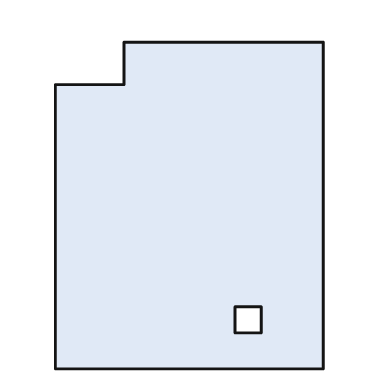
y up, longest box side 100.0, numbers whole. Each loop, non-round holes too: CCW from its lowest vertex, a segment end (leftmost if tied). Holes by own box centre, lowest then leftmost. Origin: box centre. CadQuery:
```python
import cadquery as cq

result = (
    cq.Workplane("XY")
    .moveTo(-41.0, -50.0)
    .lineTo(41.0, -50.0)
    .lineTo(41.0, 50.0)
    .lineTo(-20.0, 50.0)
    .lineTo(-20.0, 37.0)
    .lineTo(-41.0, 37.0)
    .close()
    .moveTo(14.0, -39.0)
    .lineTo(22.0, -39.0)
    .lineTo(22.0, -31.0)
    .lineTo(14.0, -31.0)
    .close()
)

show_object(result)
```